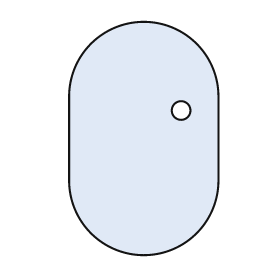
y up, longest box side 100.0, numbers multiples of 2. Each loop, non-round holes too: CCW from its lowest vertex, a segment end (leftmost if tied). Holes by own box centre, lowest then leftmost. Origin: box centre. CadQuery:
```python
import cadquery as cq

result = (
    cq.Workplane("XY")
    .moveTo(-32.0, -18.0)
    .threePointArc((0.0, -50.0), (32.0, -18.0))
    .lineTo(32.0, 18.0)
    .threePointArc((0.0, 50.0), (-32.0, 18.0))
    .close()
    .moveTo(16.0, 12.0)
    .circle(4.0)
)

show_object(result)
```